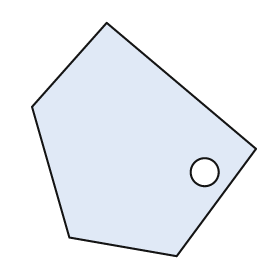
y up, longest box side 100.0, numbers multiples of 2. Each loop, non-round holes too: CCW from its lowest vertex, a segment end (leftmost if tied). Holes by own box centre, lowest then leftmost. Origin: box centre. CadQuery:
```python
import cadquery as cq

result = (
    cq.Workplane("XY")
    .moveTo(14.0, -50.0)
    .lineTo(48.0, -4.0)
    .lineTo(-16.0, 50.0)
    .lineTo(-48.0, 14.0)
    .lineTo(-32.0, -42.0)
    .close()
    .moveTo(26.0, -14.0)
    .circle(6.0)
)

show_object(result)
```